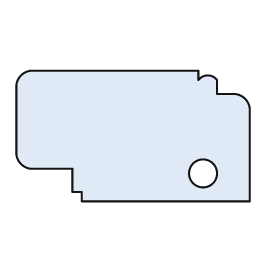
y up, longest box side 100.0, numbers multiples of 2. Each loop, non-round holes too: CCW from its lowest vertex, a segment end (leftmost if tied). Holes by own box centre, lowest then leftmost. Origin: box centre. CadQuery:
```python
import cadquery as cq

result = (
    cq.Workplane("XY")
    .moveTo(-22.0, -28.0)
    .lineTo(50.0, -28.0)
    .lineTo(50.0, 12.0)
    .threePointArc((48.0, 16.0), (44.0, 18.0))
    .lineTo(36.0, 18.0)
    .lineTo(36.0, 24.0)
    .threePointArc((32.0, 26.0), (28.0, 24.0))
    .lineTo(28.0, 28.0)
    .lineTo(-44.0, 28.0)
    .threePointArc((-48.0, 26.0), (-50.0, 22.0))
    .lineTo(-50.0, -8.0)
    .threePointArc((-48.0, -12.0), (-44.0, -14.0))
    .lineTo(-26.0, -14.0)
    .lineTo(-26.0, -24.0)
    .lineTo(-22.0, -24.0)
    .close()
    .moveTo(30.0, -16.0)
    .circle(6.0)
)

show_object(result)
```